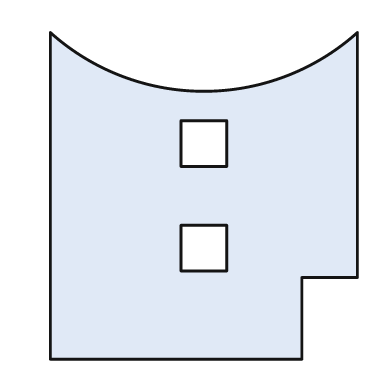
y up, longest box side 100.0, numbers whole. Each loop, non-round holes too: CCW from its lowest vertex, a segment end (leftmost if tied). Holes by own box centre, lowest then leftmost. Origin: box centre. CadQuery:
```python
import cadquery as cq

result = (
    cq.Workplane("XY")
    .moveTo(-47.0, -50.0)
    .lineTo(30.0, -50.0)
    .lineTo(30.0, -25.0)
    .lineTo(47.0, -25.0)
    .lineTo(47.0, 50.0)
    .threePointArc((0.0, 32.0), (-47.0, 50.0))
    .close()
    .moveTo(-7.0, -23.0)
    .lineTo(7.0, -23.0)
    .lineTo(7.0, -9.0)
    .lineTo(-7.0, -9.0)
    .close()
    .moveTo(-7.0, 9.0)
    .lineTo(7.0, 9.0)
    .lineTo(7.0, 23.0)
    .lineTo(-7.0, 23.0)
    .close()
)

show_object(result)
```